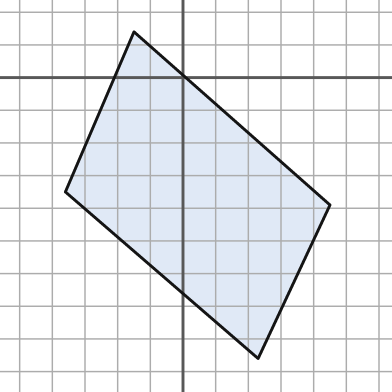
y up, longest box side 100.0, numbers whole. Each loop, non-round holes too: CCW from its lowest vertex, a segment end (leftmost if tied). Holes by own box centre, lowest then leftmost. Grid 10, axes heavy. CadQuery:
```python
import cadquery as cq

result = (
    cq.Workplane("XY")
    .moveTo(23.0, -86.0)
    .lineTo(45.0, -39.0)
    .lineTo(-15.0, 14.0)
    .lineTo(-36.0, -35.0)
    .close()
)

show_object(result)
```